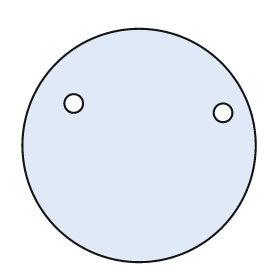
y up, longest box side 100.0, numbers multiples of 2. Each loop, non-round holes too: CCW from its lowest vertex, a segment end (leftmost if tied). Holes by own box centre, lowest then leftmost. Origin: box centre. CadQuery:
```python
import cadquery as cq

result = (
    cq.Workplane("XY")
    .moveTo(0.0, 0.0)
    .circle(50.0)
    .moveTo(36.0, 14.0)
    .circle(4.0)
    .moveTo(-28.0, 18.0)
    .circle(4.0)
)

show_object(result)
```